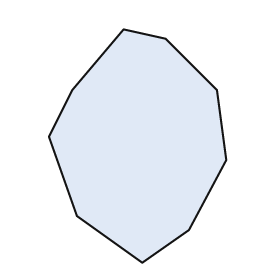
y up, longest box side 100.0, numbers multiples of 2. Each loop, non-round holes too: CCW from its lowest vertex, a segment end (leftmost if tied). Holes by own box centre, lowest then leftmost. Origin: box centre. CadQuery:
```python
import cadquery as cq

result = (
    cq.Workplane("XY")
    .moveTo(2.0, -50.0)
    .lineTo(22.0, -36.0)
    .lineTo(38.0, -6.0)
    .lineTo(34.0, 24.0)
    .lineTo(12.0, 46.0)
    .lineTo(-6.0, 50.0)
    .lineTo(-28.0, 24.0)
    .lineTo(-38.0, 4.0)
    .lineTo(-26.0, -30.0)
    .close()
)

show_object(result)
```